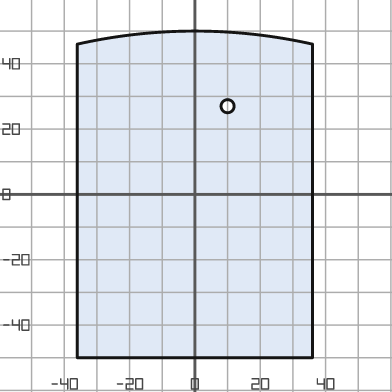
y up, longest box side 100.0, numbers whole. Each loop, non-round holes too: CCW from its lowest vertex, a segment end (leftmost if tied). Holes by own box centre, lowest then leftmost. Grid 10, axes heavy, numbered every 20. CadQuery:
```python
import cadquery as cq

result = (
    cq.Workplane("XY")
    .moveTo(-36.0, -50.0)
    .lineTo(36.0, -50.0)
    .lineTo(36.0, 46.0)
    .threePointArc((0.0, 50.0), (-36.0, 46.0))
    .close()
    .moveTo(10.0, 27.0)
    .circle(2.0)
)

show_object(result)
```